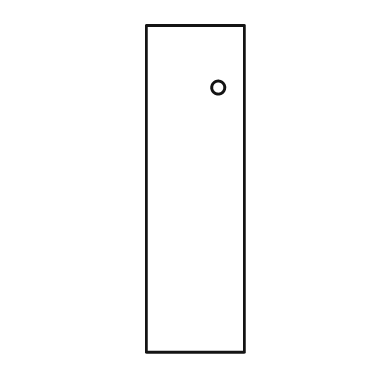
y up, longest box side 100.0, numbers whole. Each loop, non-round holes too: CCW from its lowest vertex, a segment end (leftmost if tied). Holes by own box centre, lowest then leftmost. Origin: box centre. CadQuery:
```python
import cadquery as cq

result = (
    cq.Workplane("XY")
    .moveTo(-15.0, -50.0)
    .lineTo(15.0, -50.0)
    .lineTo(15.0, 50.0)
    .lineTo(-15.0, 50.0)
    .close()
    .moveTo(7.0, 31.0)
    .circle(2.0)
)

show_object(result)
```